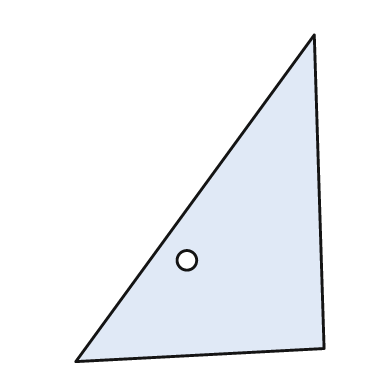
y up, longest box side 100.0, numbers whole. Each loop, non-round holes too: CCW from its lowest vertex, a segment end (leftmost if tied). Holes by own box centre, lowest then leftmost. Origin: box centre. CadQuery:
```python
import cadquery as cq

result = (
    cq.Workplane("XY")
    .moveTo(-38.0, -50.0)
    .lineTo(38.0, -46.0)
    .lineTo(35.0, 50.0)
    .close()
    .moveTo(-4.0, -19.0)
    .circle(3.0)
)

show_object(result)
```